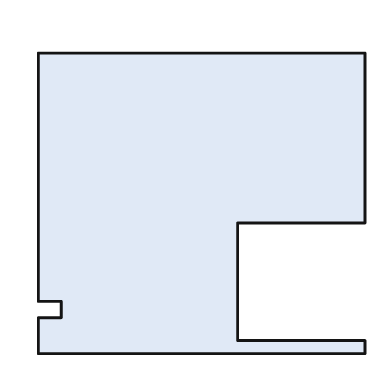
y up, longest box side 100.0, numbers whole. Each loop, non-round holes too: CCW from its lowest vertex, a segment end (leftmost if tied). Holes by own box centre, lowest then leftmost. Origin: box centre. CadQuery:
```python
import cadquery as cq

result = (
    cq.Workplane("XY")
    .moveTo(-50.0, -46.0)
    .lineTo(50.0, -46.0)
    .lineTo(50.0, -42.0)
    .lineTo(11.0, -42.0)
    .lineTo(11.0, -6.0)
    .lineTo(50.0, -6.0)
    .lineTo(50.0, 46.0)
    .lineTo(-50.0, 46.0)
    .lineTo(-50.0, -30.0)
    .lineTo(-43.0, -30.0)
    .lineTo(-43.0, -35.0)
    .lineTo(-50.0, -35.0)
    .close()
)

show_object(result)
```